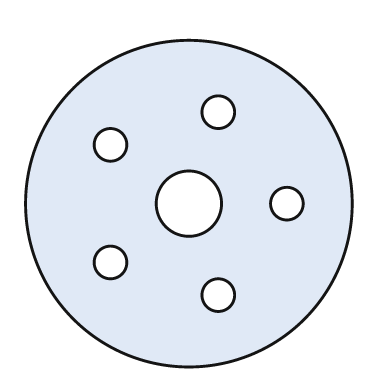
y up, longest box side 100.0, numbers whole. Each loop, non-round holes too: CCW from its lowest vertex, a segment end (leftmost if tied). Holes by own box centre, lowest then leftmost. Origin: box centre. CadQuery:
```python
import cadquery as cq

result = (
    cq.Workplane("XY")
    .moveTo(0.0, 0.0)
    .circle(50.0)
    .moveTo(9.0, -28.0)
    .circle(5.0)
    .moveTo(-24.0, -18.0)
    .circle(5.0)
    .moveTo(0.0, 0.0)
    .circle(10.0)
    .moveTo(30.0, 0.0)
    .circle(5.0)
    .moveTo(-24.0, 18.0)
    .circle(5.0)
    .moveTo(9.0, 28.0)
    .circle(5.0)
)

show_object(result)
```